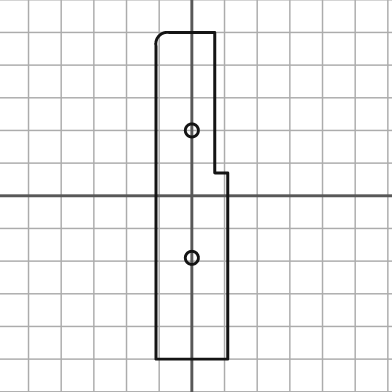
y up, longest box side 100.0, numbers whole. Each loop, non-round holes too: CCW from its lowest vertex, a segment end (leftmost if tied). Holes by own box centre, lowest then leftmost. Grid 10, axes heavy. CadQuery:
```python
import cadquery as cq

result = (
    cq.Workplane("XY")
    .moveTo(-11.0, -50.0)
    .lineTo(11.0, -50.0)
    .lineTo(11.0, 7.0)
    .lineTo(7.0, 7.0)
    .lineTo(7.0, 50.0)
    .lineTo(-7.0, 50.0)
    .threePointArc((-10.0, 49.0), (-11.0, 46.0))
    .close()
    .moveTo(0.0, -19.0)
    .circle(2.0)
    .moveTo(0.0, 20.0)
    .circle(2.0)
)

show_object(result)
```